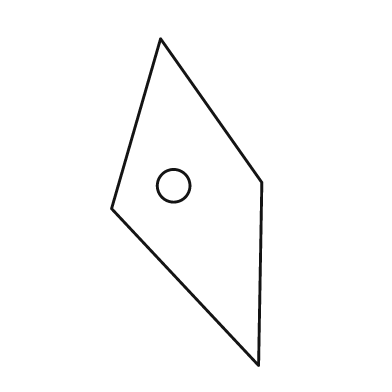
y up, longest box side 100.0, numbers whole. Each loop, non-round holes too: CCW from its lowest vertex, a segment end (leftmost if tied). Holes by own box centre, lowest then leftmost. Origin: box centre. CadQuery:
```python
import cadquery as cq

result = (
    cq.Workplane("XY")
    .moveTo(22.0, -50.0)
    .lineTo(23.0, 6.0)
    .lineTo(-8.0, 50.0)
    .lineTo(-23.0, -2.0)
    .close()
    .moveTo(-4.0, 5.0)
    .circle(5.0)
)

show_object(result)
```